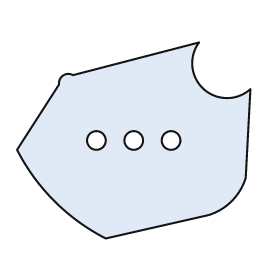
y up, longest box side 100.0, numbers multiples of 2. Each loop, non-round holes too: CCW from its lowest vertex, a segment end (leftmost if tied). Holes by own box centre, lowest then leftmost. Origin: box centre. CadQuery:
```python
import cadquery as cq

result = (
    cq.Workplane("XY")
    .moveTo(-12.0, -42.0)
    .lineTo(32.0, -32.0)
    .threePointArc((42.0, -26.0), (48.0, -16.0))
    .lineTo(50.0, 22.0)
    .threePointArc((30.0, 22.0), (28.0, 42.0))
    .lineTo(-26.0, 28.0)
    .threePointArc((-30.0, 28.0), (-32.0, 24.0))
    .lineTo(-50.0, -4.0)
    .threePointArc((-34.0, -26.0), (-12.0, -42.0))
    .close()
    .moveTo(-16.0, 0.0)
    .circle(4.0)
    .moveTo(0.0, 0.0)
    .circle(4.0)
    .moveTo(16.0, 0.0)
    .circle(4.0)
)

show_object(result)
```